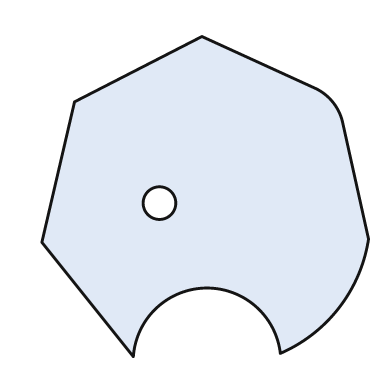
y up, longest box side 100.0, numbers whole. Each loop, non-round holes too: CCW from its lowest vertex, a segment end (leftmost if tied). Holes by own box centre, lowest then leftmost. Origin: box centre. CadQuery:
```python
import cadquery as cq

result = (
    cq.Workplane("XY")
    .moveTo(-22.0, -49.0)
    .threePointArc((0.0, -28.0), (23.0, -48.0))
    .threePointArc((41.0, -34.0), (50.0, -13.0))
    .lineTo(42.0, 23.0)
    .threePointArc((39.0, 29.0), (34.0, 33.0))
    .lineTo(-1.0, 49.0)
    .lineTo(-40.0, 29.0)
    .lineTo(-50.0, -14.0)
    .close()
    .moveTo(-14.0, -2.0)
    .circle(5.0)
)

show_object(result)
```